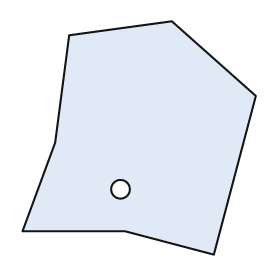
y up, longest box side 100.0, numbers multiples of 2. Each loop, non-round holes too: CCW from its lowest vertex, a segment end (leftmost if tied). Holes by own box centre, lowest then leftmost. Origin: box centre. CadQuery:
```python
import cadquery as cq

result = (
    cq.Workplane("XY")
    .moveTo(32.0, -50.0)
    .lineTo(50.0, 18.0)
    .lineTo(14.0, 50.0)
    .lineTo(-30.0, 44.0)
    .lineTo(-36.0, -2.0)
    .lineTo(-50.0, -40.0)
    .lineTo(-6.0, -40.0)
    .close()
    .moveTo(-8.0, -22.0)
    .circle(4.0)
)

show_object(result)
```